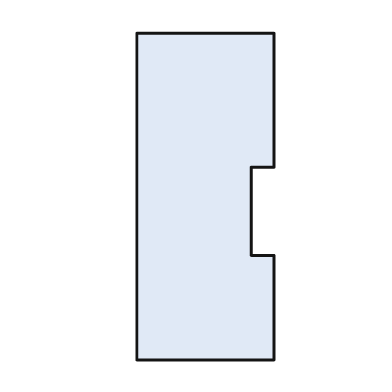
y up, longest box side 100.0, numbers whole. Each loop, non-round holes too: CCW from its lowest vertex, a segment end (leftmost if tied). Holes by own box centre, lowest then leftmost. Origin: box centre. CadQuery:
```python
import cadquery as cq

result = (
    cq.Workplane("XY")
    .moveTo(-21.0, -50.0)
    .lineTo(21.0, -50.0)
    .lineTo(21.0, -18.0)
    .lineTo(14.0, -18.0)
    .lineTo(14.0, 9.0)
    .lineTo(21.0, 9.0)
    .lineTo(21.0, 50.0)
    .lineTo(-21.0, 50.0)
    .close()
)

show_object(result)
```